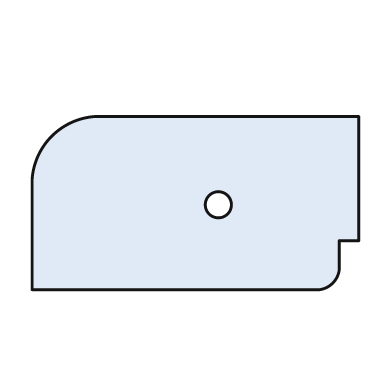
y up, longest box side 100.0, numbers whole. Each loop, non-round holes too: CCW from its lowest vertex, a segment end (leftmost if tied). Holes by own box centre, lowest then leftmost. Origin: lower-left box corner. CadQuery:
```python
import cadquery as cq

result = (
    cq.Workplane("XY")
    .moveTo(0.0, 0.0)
    .lineTo(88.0, 0.0)
    .threePointArc((92.0, 2.0), (94.0, 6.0))
    .lineTo(94.0, 15.0)
    .lineTo(100.0, 15.0)
    .lineTo(100.0, 53.0)
    .lineTo(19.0, 53.0)
    .threePointArc((6.0, 47.0), (0.0, 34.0))
    .close()
    .moveTo(57.0, 26.0)
    .circle(4.0)
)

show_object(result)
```